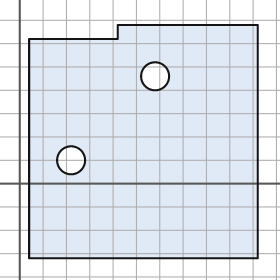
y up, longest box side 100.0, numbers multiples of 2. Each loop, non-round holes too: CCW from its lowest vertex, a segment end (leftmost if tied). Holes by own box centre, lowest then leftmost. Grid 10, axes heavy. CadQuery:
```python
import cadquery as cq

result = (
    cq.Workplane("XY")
    .moveTo(4.0, -32.0)
    .lineTo(102.0, -32.0)
    .lineTo(102.0, 68.0)
    .lineTo(42.0, 68.0)
    .lineTo(42.0, 62.0)
    .lineTo(4.0, 62.0)
    .close()
    .moveTo(22.0, 10.0)
    .circle(6.0)
    .moveTo(58.0, 46.0)
    .circle(6.0)
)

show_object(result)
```